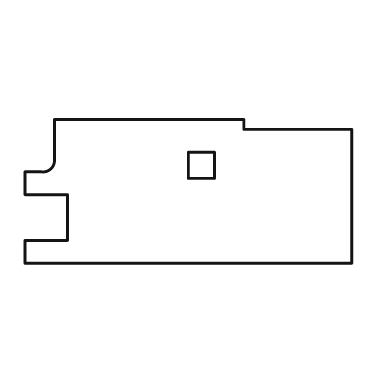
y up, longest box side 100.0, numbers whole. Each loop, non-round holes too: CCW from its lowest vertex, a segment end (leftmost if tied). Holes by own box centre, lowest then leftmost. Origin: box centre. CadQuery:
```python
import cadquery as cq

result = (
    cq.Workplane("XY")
    .moveTo(-50.0, -22.0)
    .lineTo(50.0, -22.0)
    .lineTo(50.0, 19.0)
    .lineTo(17.0, 19.0)
    .lineTo(17.0, 22.0)
    .lineTo(-41.0, 22.0)
    .lineTo(-41.0, 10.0)
    .threePointArc((-42.0, 7.0), (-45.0, 6.0))
    .lineTo(-50.0, 6.0)
    .lineTo(-50.0, -1.0)
    .lineTo(-37.0, -1.0)
    .lineTo(-37.0, -15.0)
    .lineTo(-50.0, -15.0)
    .close()
    .moveTo(0.0, 4.0)
    .lineTo(8.0, 4.0)
    .lineTo(8.0, 12.0)
    .lineTo(0.0, 12.0)
    .close()
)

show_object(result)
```